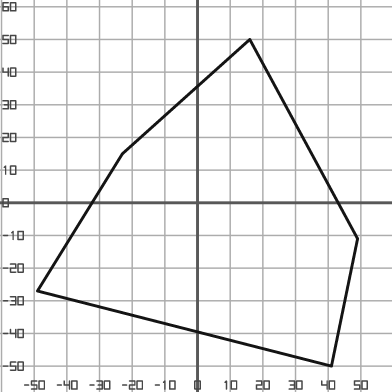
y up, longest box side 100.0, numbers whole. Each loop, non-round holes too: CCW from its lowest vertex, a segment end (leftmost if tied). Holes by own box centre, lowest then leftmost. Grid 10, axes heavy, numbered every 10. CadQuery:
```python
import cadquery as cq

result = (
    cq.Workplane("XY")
    .moveTo(41.0, -50.0)
    .lineTo(49.0, -11.0)
    .lineTo(16.0, 50.0)
    .lineTo(-23.0, 15.0)
    .lineTo(-49.0, -27.0)
    .close()
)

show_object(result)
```